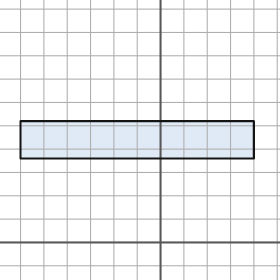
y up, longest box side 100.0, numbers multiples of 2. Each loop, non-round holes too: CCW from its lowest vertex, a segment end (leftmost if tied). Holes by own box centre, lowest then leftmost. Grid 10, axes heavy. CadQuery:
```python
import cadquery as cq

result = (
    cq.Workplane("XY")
    .moveTo(-60.0, 36.0)
    .lineTo(40.0, 36.0)
    .lineTo(40.0, 52.0)
    .lineTo(-60.0, 52.0)
    .close()
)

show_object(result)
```